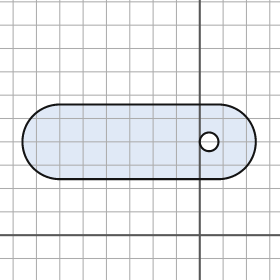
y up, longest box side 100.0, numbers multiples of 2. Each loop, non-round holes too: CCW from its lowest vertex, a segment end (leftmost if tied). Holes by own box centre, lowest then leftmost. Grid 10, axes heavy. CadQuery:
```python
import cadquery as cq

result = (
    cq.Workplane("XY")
    .moveTo(-60.0, 24.0)
    .lineTo(8.0, 24.0)
    .threePointArc((24.0, 40.0), (8.0, 56.0))
    .lineTo(-60.0, 56.0)
    .threePointArc((-76.0, 40.0), (-60.0, 24.0))
    .close()
    .moveTo(4.0, 40.0)
    .circle(4.0)
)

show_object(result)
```